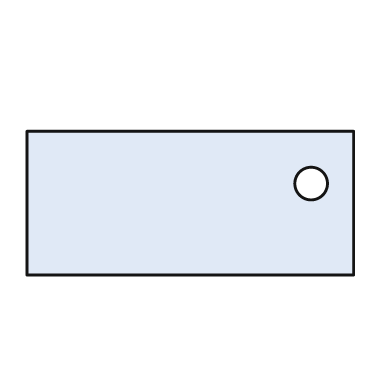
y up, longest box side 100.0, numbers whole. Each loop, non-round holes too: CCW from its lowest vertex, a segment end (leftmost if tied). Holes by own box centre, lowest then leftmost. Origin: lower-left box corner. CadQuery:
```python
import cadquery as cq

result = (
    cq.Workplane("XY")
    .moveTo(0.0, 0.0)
    .lineTo(100.0, 0.0)
    .lineTo(100.0, 44.0)
    .lineTo(0.0, 44.0)
    .close()
    .moveTo(87.0, 28.0)
    .circle(5.0)
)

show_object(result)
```